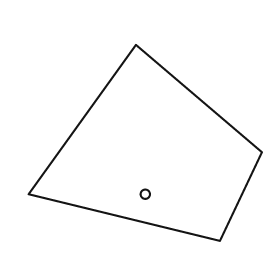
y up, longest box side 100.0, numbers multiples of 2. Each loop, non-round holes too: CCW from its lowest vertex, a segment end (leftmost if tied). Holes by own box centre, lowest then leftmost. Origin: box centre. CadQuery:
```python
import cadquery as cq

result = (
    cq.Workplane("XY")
    .moveTo(32.0, -42.0)
    .lineTo(50.0, -4.0)
    .lineTo(-4.0, 42.0)
    .lineTo(-50.0, -22.0)
    .close()
    .moveTo(0.0, -22.0)
    .circle(2.0)
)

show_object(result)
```